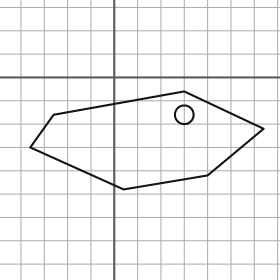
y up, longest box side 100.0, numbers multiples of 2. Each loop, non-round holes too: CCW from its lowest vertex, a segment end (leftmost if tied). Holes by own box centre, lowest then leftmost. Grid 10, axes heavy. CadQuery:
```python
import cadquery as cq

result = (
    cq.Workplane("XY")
    .moveTo(4.0, -48.0)
    .lineTo(40.0, -42.0)
    .lineTo(64.0, -22.0)
    .lineTo(30.0, -6.0)
    .lineTo(-26.0, -16.0)
    .lineTo(-36.0, -30.0)
    .close()
    .moveTo(30.0, -16.0)
    .circle(4.0)
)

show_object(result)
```